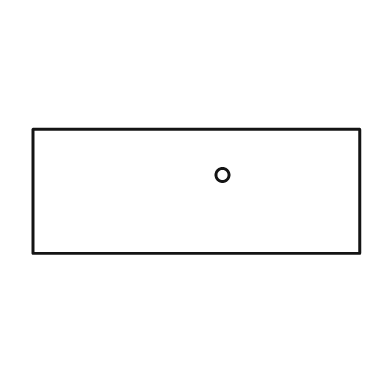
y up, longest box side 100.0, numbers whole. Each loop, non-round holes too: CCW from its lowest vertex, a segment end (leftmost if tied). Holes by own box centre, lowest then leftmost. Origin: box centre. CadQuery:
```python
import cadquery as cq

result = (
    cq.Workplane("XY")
    .moveTo(-50.0, -19.0)
    .lineTo(50.0, -19.0)
    .lineTo(50.0, 19.0)
    .lineTo(-50.0, 19.0)
    .close()
    .moveTo(8.0, 5.0)
    .circle(2.0)
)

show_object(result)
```